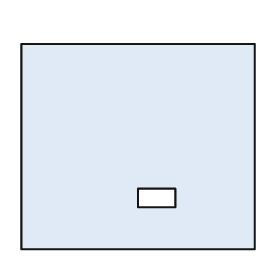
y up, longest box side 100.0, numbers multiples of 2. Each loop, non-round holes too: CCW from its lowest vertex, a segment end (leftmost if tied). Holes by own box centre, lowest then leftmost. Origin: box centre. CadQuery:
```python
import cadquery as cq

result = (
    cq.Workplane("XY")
    .moveTo(-50.0, -44.0)
    .lineTo(50.0, -44.0)
    .lineTo(50.0, 44.0)
    .lineTo(-50.0, 44.0)
    .close()
    .moveTo(0.0, -26.0)
    .lineTo(16.0, -26.0)
    .lineTo(16.0, -18.0)
    .lineTo(0.0, -18.0)
    .close()
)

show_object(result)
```